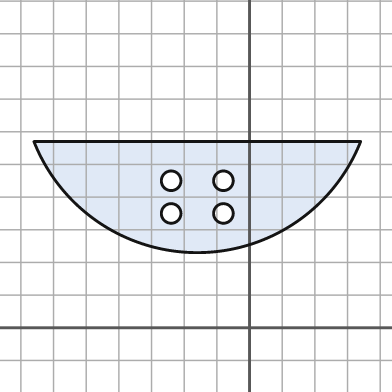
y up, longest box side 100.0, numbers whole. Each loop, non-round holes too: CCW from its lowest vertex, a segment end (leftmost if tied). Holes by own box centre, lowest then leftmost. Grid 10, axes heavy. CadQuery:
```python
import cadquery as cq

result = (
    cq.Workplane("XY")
    .moveTo(-66.0, 57.0)
    .threePointArc((-16.0, 23.0), (34.0, 57.0))
    .close()
    .moveTo(-24.0, 35.0)
    .circle(3.0)
    .moveTo(-8.0, 35.0)
    .circle(3.0)
    .moveTo(-24.0, 45.0)
    .circle(3.0)
    .moveTo(-8.0, 45.0)
    .circle(3.0)
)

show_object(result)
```